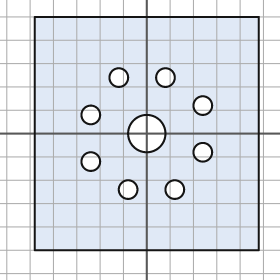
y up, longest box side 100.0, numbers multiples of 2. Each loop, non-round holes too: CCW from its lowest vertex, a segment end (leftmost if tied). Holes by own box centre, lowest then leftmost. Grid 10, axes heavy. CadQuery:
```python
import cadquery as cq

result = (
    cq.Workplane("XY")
    .moveTo(-48.0, -50.0)
    .lineTo(48.0, -50.0)
    .lineTo(48.0, 50.0)
    .lineTo(-48.0, 50.0)
    .close()
    .moveTo(-8.0, -24.0)
    .circle(4.0)
    .moveTo(12.0, -24.0)
    .circle(4.0)
    .moveTo(-24.0, -12.0)
    .circle(4.0)
    .moveTo(24.0, -8.0)
    .circle(4.0)
    .moveTo(0.0, 0.0)
    .circle(8.0)
    .moveTo(-24.0, 8.0)
    .circle(4.0)
    .moveTo(24.0, 12.0)
    .circle(4.0)
    .moveTo(-12.0, 24.0)
    .circle(4.0)
    .moveTo(8.0, 24.0)
    .circle(4.0)
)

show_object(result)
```